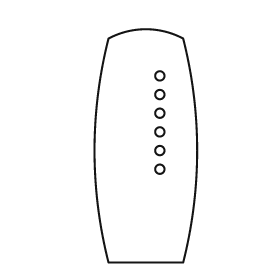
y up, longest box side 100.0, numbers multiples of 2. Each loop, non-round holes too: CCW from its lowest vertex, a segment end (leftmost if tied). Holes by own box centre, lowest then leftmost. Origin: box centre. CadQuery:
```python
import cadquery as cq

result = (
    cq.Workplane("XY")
    .moveTo(-16.0, -50.0)
    .lineTo(16.0, -50.0)
    .threePointArc((22.0, -2.0), (16.0, 46.0))
    .threePointArc((0.0, 50.0), (-16.0, 46.0))
    .threePointArc((-22.0, -2.0), (-16.0, -50.0))
    .close()
    .moveTo(6.0, -10.0)
    .circle(2.0)
    .moveTo(6.0, -2.0)
    .circle(2.0)
    .moveTo(6.0, 6.0)
    .circle(2.0)
    .moveTo(6.0, 14.0)
    .circle(2.0)
    .moveTo(6.0, 22.0)
    .circle(2.0)
    .moveTo(6.0, 30.0)
    .circle(2.0)
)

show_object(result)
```